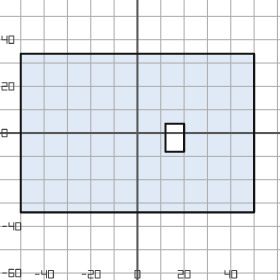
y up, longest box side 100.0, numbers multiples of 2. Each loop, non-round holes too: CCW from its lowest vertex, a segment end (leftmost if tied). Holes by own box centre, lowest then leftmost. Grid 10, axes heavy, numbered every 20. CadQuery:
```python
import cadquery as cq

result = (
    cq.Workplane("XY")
    .moveTo(-50.0, -34.0)
    .lineTo(50.0, -34.0)
    .lineTo(50.0, 34.0)
    .lineTo(-50.0, 34.0)
    .close()
    .moveTo(12.0, -8.0)
    .lineTo(20.0, -8.0)
    .lineTo(20.0, 4.0)
    .lineTo(12.0, 4.0)
    .close()
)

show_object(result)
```